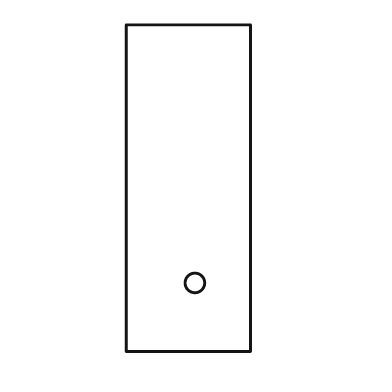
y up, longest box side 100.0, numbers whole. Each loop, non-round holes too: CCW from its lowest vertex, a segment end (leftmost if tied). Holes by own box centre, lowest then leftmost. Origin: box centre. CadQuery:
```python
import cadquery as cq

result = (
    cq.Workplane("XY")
    .moveTo(-19.0, -50.0)
    .lineTo(19.0, -50.0)
    .lineTo(19.0, 50.0)
    .lineTo(-19.0, 50.0)
    .close()
    .moveTo(2.0, -29.0)
    .circle(3.0)
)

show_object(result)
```